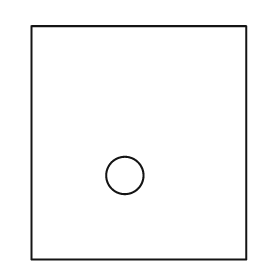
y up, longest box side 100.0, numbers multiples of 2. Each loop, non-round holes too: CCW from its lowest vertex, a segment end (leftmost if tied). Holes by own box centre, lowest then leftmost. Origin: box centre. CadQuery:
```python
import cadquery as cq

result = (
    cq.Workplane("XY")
    .moveTo(-46.0, -50.0)
    .lineTo(46.0, -50.0)
    .lineTo(46.0, 50.0)
    .lineTo(-46.0, 50.0)
    .close()
    .moveTo(-6.0, -14.0)
    .circle(8.0)
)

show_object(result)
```